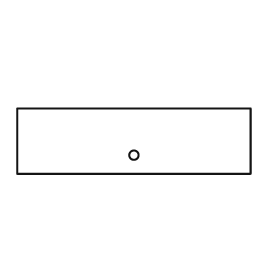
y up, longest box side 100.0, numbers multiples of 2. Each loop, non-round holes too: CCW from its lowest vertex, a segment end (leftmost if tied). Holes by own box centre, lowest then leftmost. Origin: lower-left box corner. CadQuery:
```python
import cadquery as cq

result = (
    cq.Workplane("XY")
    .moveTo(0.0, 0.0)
    .lineTo(100.0, 0.0)
    .lineTo(100.0, 28.0)
    .lineTo(0.0, 28.0)
    .close()
    .moveTo(50.0, 8.0)
    .circle(2.0)
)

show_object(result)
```